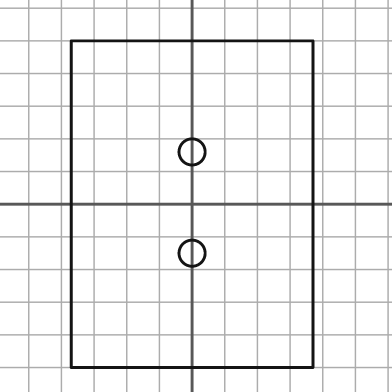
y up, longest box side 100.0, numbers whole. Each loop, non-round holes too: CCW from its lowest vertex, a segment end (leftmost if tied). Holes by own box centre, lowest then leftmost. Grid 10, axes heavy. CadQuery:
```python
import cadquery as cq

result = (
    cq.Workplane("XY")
    .moveTo(-37.0, -50.0)
    .lineTo(37.0, -50.0)
    .lineTo(37.0, 50.0)
    .lineTo(-37.0, 50.0)
    .close()
    .moveTo(0.0, -15.0)
    .circle(4.0)
    .moveTo(0.0, 16.0)
    .circle(4.0)
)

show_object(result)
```